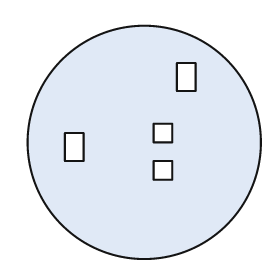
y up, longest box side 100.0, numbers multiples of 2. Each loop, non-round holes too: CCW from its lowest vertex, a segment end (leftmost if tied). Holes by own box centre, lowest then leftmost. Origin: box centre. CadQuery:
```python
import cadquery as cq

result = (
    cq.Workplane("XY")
    .moveTo(0.0, 0.0)
    .circle(50.0)
    .moveTo(4.0, -16.0)
    .lineTo(12.0, -16.0)
    .lineTo(12.0, -8.0)
    .lineTo(4.0, -8.0)
    .close()
    .moveTo(-34.0, -8.0)
    .lineTo(-26.0, -8.0)
    .lineTo(-26.0, 4.0)
    .lineTo(-34.0, 4.0)
    .close()
    .moveTo(4.0, 0.0)
    .lineTo(12.0, 0.0)
    .lineTo(12.0, 8.0)
    .lineTo(4.0, 8.0)
    .close()
    .moveTo(14.0, 22.0)
    .lineTo(22.0, 22.0)
    .lineTo(22.0, 34.0)
    .lineTo(14.0, 34.0)
    .close()
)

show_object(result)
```